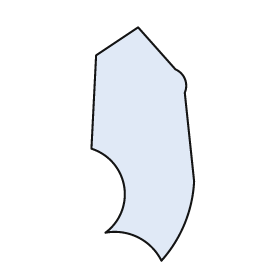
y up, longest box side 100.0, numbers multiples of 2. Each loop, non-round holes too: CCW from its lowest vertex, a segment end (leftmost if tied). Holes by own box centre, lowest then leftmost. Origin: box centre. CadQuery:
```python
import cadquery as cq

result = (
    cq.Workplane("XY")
    .moveTo(8.0, -50.0)
    .threePointArc((18.0, -34.0), (22.0, -16.0))
    .lineTo(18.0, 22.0)
    .threePointArc((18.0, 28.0), (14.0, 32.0))
    .lineTo(-2.0, 50.0)
    .lineTo(-20.0, 38.0)
    .lineTo(-22.0, -2.0)
    .threePointArc((-8.0, -18.0), (-16.0, -38.0))
    .threePointArc((-2.0, -40.0), (8.0, -50.0))
    .close()
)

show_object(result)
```